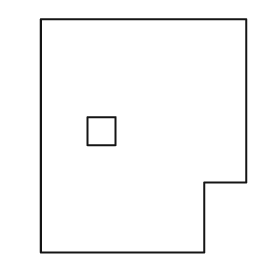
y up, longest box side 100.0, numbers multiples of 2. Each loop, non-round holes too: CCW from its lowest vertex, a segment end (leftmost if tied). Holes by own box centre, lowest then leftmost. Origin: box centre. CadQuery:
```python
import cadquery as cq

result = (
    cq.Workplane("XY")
    .moveTo(-44.0, -50.0)
    .lineTo(26.0, -50.0)
    .lineTo(26.0, -20.0)
    .lineTo(44.0, -20.0)
    .lineTo(44.0, 50.0)
    .lineTo(-44.0, 50.0)
    .close()
    .moveTo(-24.0, -4.0)
    .lineTo(-12.0, -4.0)
    .lineTo(-12.0, 8.0)
    .lineTo(-24.0, 8.0)
    .close()
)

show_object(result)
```